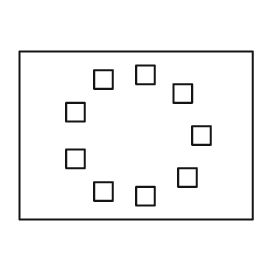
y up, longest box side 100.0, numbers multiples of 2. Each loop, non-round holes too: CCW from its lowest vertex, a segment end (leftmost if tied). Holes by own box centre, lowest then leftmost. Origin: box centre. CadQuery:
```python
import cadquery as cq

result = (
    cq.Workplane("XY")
    .moveTo(-50.0, -36.0)
    .lineTo(50.0, -36.0)
    .lineTo(50.0, 36.0)
    .lineTo(-50.0, 36.0)
    .close()
    .moveTo(0.0, -30.0)
    .lineTo(8.0, -30.0)
    .lineTo(8.0, -22.0)
    .lineTo(0.0, -22.0)
    .close()
    .moveTo(-18.0, -28.0)
    .lineTo(-10.0, -28.0)
    .lineTo(-10.0, -20.0)
    .lineTo(-18.0, -20.0)
    .close()
    .moveTo(18.0, -22.0)
    .lineTo(26.0, -22.0)
    .lineTo(26.0, -14.0)
    .lineTo(18.0, -14.0)
    .close()
    .moveTo(-30.0, -14.0)
    .lineTo(-22.0, -14.0)
    .lineTo(-22.0, -6.0)
    .lineTo(-30.0, -6.0)
    .close()
    .moveTo(24.0, -4.0)
    .lineTo(32.0, -4.0)
    .lineTo(32.0, 4.0)
    .lineTo(24.0, 4.0)
    .close()
    .moveTo(-30.0, 6.0)
    .lineTo(-22.0, 6.0)
    .lineTo(-22.0, 14.0)
    .lineTo(-30.0, 14.0)
    .close()
    .moveTo(16.0, 14.0)
    .lineTo(24.0, 14.0)
    .lineTo(24.0, 22.0)
    .lineTo(16.0, 22.0)
    .close()
    .moveTo(-18.0, 20.0)
    .lineTo(-10.0, 20.0)
    .lineTo(-10.0, 28.0)
    .lineTo(-18.0, 28.0)
    .close()
    .moveTo(0.0, 22.0)
    .lineTo(8.0, 22.0)
    .lineTo(8.0, 30.0)
    .lineTo(0.0, 30.0)
    .close()
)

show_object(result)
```